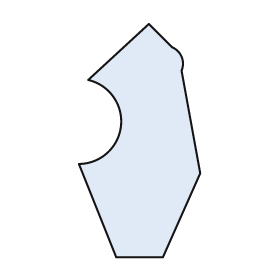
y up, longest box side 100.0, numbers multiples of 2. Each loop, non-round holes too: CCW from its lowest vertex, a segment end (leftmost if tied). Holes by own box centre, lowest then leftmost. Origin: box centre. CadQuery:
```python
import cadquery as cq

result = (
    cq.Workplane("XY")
    .moveTo(-10.0, -50.0)
    .lineTo(10.0, -50.0)
    .lineTo(26.0, -14.0)
    .lineTo(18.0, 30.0)
    .threePointArc((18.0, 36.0), (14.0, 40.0))
    .lineTo(4.0, 50.0)
    .lineTo(-22.0, 26.0)
    .threePointArc((-8.0, 6.0), (-26.0, -10.0))
    .close()
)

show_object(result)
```